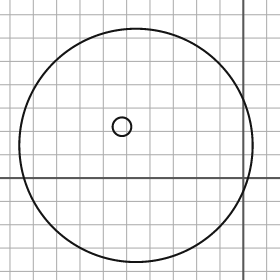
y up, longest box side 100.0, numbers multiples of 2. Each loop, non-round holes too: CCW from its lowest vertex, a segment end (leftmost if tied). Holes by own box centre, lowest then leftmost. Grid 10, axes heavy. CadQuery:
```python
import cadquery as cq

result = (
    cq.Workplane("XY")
    .moveTo(-46.0, 14.0)
    .circle(50.0)
    .moveTo(-52.0, 22.0)
    .circle(4.0)
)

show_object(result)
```